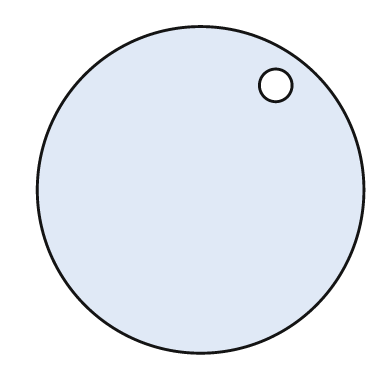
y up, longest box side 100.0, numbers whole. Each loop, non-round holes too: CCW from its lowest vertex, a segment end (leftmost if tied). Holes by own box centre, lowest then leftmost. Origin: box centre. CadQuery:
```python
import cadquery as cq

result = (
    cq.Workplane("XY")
    .moveTo(0.0, 0.0)
    .circle(50.0)
    .moveTo(23.0, 32.0)
    .circle(5.0)
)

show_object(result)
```